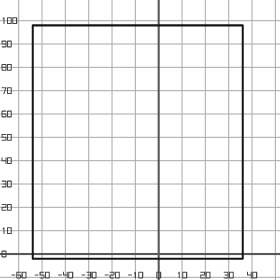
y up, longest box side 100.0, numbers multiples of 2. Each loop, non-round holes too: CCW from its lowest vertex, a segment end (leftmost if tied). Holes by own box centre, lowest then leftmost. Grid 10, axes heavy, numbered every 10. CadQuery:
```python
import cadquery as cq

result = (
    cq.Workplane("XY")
    .moveTo(-54.0, -2.0)
    .lineTo(36.0, -2.0)
    .lineTo(36.0, 98.0)
    .lineTo(-54.0, 98.0)
    .close()
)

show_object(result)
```